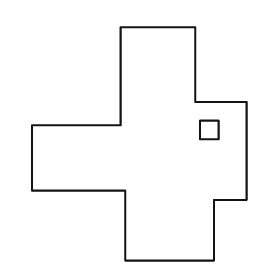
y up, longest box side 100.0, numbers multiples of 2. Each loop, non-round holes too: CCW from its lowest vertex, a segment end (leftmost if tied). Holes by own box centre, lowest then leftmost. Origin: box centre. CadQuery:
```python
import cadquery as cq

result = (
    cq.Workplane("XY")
    .moveTo(-6.0, -50.0)
    .lineTo(32.0, -50.0)
    .lineTo(32.0, -24.0)
    .lineTo(46.0, -24.0)
    .lineTo(46.0, 18.0)
    .lineTo(24.0, 18.0)
    .lineTo(24.0, 50.0)
    .lineTo(-8.0, 50.0)
    .lineTo(-8.0, 8.0)
    .lineTo(-46.0, 8.0)
    .lineTo(-46.0, -20.0)
    .lineTo(-6.0, -20.0)
    .close()
    .moveTo(26.0, 2.0)
    .lineTo(34.0, 2.0)
    .lineTo(34.0, 10.0)
    .lineTo(26.0, 10.0)
    .close()
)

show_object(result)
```